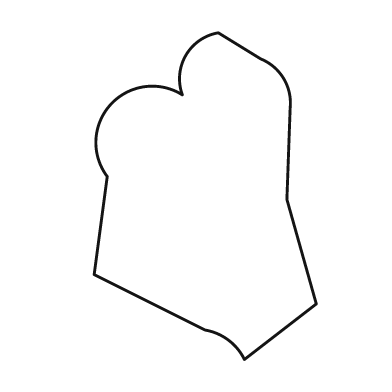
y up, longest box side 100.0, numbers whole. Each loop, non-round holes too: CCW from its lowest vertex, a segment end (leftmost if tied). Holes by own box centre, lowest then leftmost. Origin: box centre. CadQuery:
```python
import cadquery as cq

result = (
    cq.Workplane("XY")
    .moveTo(12.0, -50.0)
    .lineTo(34.0, -33.0)
    .lineTo(25.0, -1.0)
    .lineTo(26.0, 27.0)
    .threePointArc((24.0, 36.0), (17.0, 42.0))
    .lineTo(4.0, 50.0)
    .threePointArc((-6.0, 43.0), (-7.0, 31.0))
    .threePointArc((-29.0, 28.0), (-30.0, 6.0))
    .lineTo(-34.0, -24.0)
    .lineTo(0.0, -41.0)
    .threePointArc((7.0, -44.0), (12.0, -50.0))
    .close()
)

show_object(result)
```